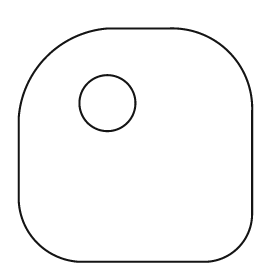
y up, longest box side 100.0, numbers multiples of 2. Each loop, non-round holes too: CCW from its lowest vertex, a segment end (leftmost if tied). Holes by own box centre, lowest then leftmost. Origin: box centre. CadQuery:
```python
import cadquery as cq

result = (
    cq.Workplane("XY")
    .moveTo(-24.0, -50.0)
    .lineTo(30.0, -50.0)
    .threePointArc((44.0, -44.0), (50.0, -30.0))
    .lineTo(50.0, 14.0)
    .threePointArc((40.0, 40.0), (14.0, 50.0))
    .lineTo(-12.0, 50.0)
    .threePointArc((-38.0, 38.0), (-50.0, 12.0))
    .lineTo(-50.0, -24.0)
    .threePointArc((-42.0, -42.0), (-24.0, -50.0))
    .close()
    .moveTo(-12.0, 18.0)
    .circle(12.0)
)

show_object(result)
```